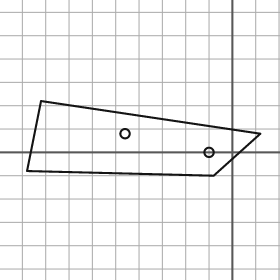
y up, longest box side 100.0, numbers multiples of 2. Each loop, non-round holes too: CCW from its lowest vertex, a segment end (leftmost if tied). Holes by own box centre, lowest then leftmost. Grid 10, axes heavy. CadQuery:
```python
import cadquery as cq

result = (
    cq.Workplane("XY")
    .moveTo(-8.0, -10.0)
    .lineTo(12.0, 8.0)
    .lineTo(-82.0, 22.0)
    .lineTo(-88.0, -8.0)
    .close()
    .moveTo(-10.0, 0.0)
    .circle(2.0)
    .moveTo(-46.0, 8.0)
    .circle(2.0)
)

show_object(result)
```